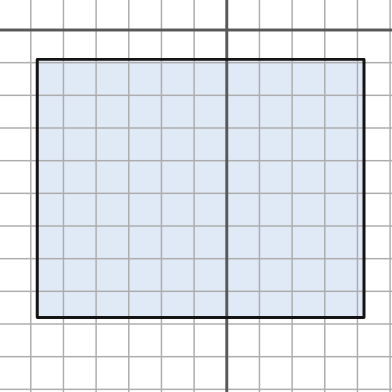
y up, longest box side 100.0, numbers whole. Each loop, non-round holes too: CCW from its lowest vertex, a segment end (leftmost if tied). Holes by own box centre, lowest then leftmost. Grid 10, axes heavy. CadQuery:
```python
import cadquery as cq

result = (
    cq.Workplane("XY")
    .moveTo(-58.0, -88.0)
    .lineTo(42.0, -88.0)
    .lineTo(42.0, -9.0)
    .lineTo(-58.0, -9.0)
    .close()
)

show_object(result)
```